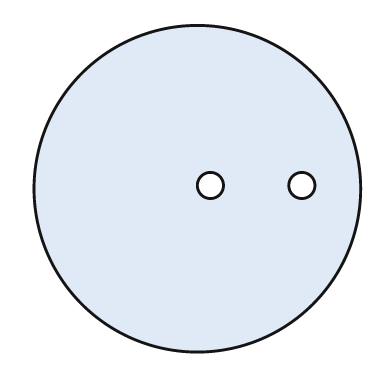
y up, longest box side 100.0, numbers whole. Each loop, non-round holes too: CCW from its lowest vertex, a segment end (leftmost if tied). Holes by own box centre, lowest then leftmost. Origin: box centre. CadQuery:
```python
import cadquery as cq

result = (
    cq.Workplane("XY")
    .moveTo(0.0, 0.0)
    .circle(50.0)
    .moveTo(4.0, 1.0)
    .circle(4.0)
    .moveTo(32.0, 1.0)
    .circle(4.0)
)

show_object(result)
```